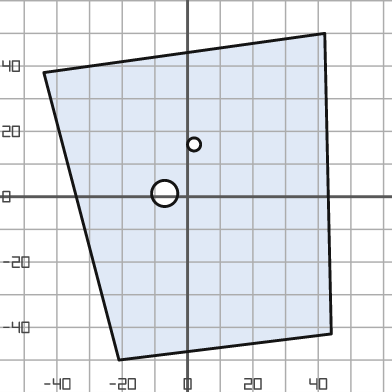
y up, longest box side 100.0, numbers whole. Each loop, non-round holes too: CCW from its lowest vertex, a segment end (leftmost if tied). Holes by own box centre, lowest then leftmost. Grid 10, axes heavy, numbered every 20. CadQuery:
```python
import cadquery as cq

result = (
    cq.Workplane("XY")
    .moveTo(-21.0, -50.0)
    .lineTo(44.0, -42.0)
    .lineTo(42.0, 50.0)
    .lineTo(-44.0, 38.0)
    .close()
    .moveTo(-7.0, 1.0)
    .circle(4.0)
    .moveTo(2.0, 16.0)
    .circle(2.0)
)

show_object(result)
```